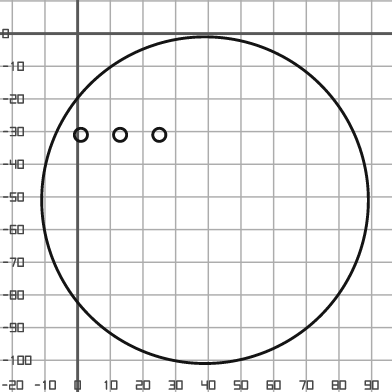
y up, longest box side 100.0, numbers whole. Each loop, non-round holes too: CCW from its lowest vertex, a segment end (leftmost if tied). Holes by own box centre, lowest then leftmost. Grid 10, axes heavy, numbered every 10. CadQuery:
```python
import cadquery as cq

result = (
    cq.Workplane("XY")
    .moveTo(39.0, -51.0)
    .circle(50.0)
    .moveTo(1.0, -31.0)
    .circle(2.0)
    .moveTo(13.0, -31.0)
    .circle(2.0)
    .moveTo(25.0, -31.0)
    .circle(2.0)
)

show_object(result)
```